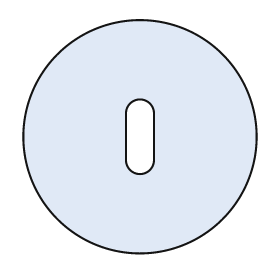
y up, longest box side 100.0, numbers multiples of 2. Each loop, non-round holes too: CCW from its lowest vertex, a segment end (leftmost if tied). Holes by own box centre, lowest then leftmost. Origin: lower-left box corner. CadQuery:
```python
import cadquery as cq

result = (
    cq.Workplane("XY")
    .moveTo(50.0, 50.0)
    .circle(50.0)
    .moveTo(44.0, 40.0)
    .threePointArc((50.0, 34.0), (56.0, 40.0))
    .lineTo(56.0, 60.0)
    .threePointArc((50.0, 66.0), (44.0, 60.0))
    .close()
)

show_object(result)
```